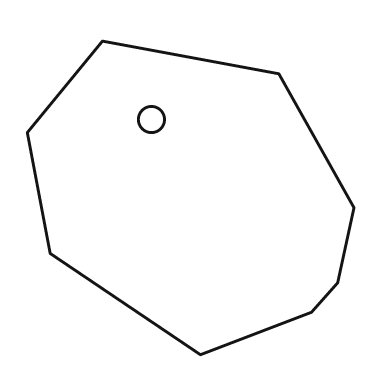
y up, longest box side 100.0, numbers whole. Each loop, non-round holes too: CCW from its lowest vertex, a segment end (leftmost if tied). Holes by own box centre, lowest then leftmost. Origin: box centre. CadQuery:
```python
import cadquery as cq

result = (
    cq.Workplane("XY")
    .moveTo(3.0, -48.0)
    .lineTo(37.0, -35.0)
    .lineTo(45.0, -26.0)
    .lineTo(50.0, -3.0)
    .lineTo(27.0, 38.0)
    .lineTo(-27.0, 48.0)
    .lineTo(-50.0, 20.0)
    .lineTo(-43.0, -17.0)
    .close()
    .moveTo(-12.0, 24.0)
    .circle(4.0)
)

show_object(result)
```